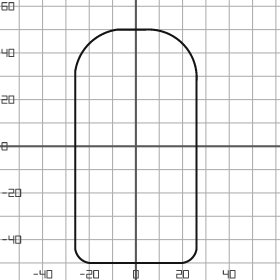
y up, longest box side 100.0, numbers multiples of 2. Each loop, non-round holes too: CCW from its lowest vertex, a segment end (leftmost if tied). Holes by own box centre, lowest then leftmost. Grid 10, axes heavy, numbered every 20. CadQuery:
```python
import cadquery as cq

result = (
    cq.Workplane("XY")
    .moveTo(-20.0, -50.0)
    .lineTo(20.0, -50.0)
    .threePointArc((24.0, -48.0), (26.0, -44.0))
    .lineTo(26.0, 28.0)
    .threePointArc((20.0, 44.0), (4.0, 50.0))
    .lineTo(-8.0, 50.0)
    .threePointArc((-20.0, 44.0), (-26.0, 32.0))
    .lineTo(-26.0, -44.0)
    .threePointArc((-24.0, -48.0), (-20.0, -50.0))
    .close()
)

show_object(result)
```